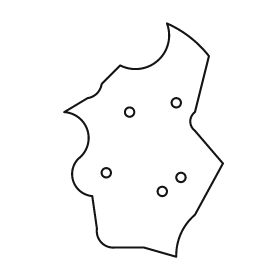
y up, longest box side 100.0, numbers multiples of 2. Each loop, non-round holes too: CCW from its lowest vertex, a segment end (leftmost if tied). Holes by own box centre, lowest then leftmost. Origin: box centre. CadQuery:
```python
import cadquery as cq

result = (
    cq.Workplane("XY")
    .moveTo(14.0, -50.0)
    .threePointArc((16.0, -40.0), (22.0, -32.0))
    .lineTo(34.0, -10.0)
    .lineTo(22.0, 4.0)
    .threePointArc((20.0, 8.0), (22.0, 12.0))
    .lineTo(28.0, 36.0)
    .threePointArc((20.0, 44.0), (10.0, 50.0))
    .threePointArc((6.0, 34.0), (-10.0, 32.0))
    .lineTo(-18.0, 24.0)
    .threePointArc((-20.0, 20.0), (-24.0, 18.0))
    .lineTo(-34.0, 12.0)
    .threePointArc((-24.0, 4.0), (-28.0, -8.0))
    .threePointArc((-30.0, -18.0), (-22.0, -24.0))
    .lineTo(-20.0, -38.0)
    .threePointArc((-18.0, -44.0), (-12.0, -46.0))
    .lineTo(0.0, -46.0)
    .close()
    .moveTo(8.0, -22.0)
    .circle(2.0)
    .moveTo(16.0, -16.0)
    .circle(2.0)
    .moveTo(-16.0, -14.0)
    .circle(2.0)
    .moveTo(-6.0, 12.0)
    .circle(2.0)
    .moveTo(14.0, 16.0)
    .circle(2.0)
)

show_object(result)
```